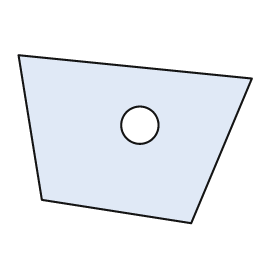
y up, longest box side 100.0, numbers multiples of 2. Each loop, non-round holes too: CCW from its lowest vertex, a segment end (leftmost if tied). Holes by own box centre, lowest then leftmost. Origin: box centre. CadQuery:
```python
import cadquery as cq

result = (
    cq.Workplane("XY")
    .moveTo(24.0, -36.0)
    .lineTo(50.0, 26.0)
    .lineTo(-50.0, 36.0)
    .lineTo(-40.0, -26.0)
    .close()
    .moveTo(2.0, 6.0)
    .circle(8.0)
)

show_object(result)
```